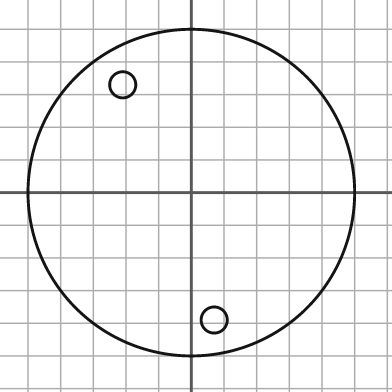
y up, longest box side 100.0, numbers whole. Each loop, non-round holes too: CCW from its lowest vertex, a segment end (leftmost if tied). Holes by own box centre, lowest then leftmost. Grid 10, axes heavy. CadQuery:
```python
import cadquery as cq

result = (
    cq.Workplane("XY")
    .moveTo(0.0, 0.0)
    .circle(50.0)
    .moveTo(7.0, -39.0)
    .circle(4.0)
    .moveTo(-21.0, 33.0)
    .circle(4.0)
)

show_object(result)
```